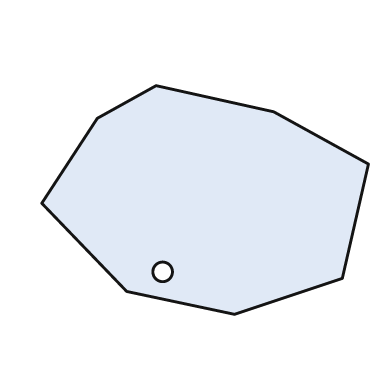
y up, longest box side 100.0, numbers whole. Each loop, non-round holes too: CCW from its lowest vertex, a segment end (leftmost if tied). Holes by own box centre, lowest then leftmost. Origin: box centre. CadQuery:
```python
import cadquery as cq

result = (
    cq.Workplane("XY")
    .moveTo(9.0, -35.0)
    .lineTo(42.0, -24.0)
    .lineTo(50.0, 11.0)
    .lineTo(21.0, 27.0)
    .lineTo(-15.0, 35.0)
    .lineTo(-33.0, 25.0)
    .lineTo(-50.0, -1.0)
    .lineTo(-24.0, -28.0)
    .close()
    .moveTo(-13.0, -22.0)
    .circle(3.0)
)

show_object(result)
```